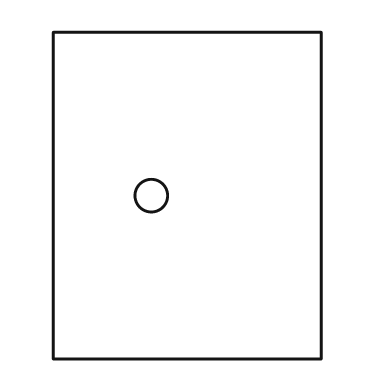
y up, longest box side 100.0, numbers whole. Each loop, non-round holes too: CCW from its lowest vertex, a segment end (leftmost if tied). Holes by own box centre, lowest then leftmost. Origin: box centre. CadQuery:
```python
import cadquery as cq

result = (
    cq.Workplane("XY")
    .moveTo(-41.0, -50.0)
    .lineTo(41.0, -50.0)
    .lineTo(41.0, 50.0)
    .lineTo(-41.0, 50.0)
    .close()
    .moveTo(-11.0, 0.0)
    .circle(5.0)
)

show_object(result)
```